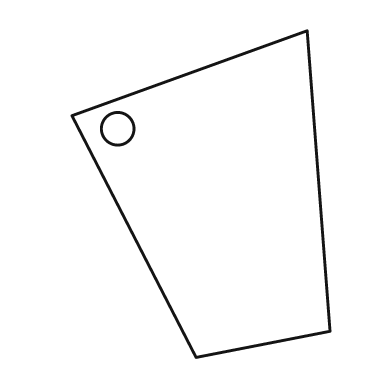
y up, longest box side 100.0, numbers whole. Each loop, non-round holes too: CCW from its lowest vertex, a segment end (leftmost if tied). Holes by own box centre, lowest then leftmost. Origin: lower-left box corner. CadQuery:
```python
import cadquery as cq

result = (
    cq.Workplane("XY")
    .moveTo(38.0, 0.0)
    .lineTo(79.0, 8.0)
    .lineTo(72.0, 100.0)
    .lineTo(0.0, 74.0)
    .close()
    .moveTo(14.0, 70.0)
    .circle(5.0)
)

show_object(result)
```